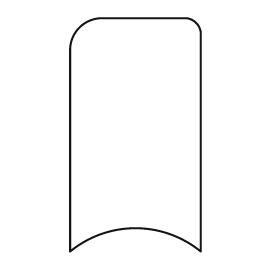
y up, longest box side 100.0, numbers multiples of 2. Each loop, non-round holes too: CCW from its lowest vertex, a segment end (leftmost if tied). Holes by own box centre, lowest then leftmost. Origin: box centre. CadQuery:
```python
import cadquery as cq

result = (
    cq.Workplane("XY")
    .moveTo(-28.0, -50.0)
    .threePointArc((0.0, -40.0), (28.0, -50.0))
    .lineTo(28.0, 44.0)
    .threePointArc((26.0, 48.0), (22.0, 50.0))
    .lineTo(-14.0, 50.0)
    .threePointArc((-24.0, 46.0), (-28.0, 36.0))
    .close()
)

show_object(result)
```